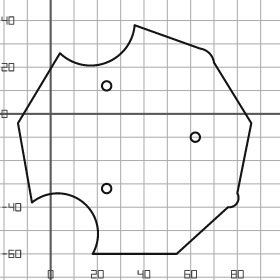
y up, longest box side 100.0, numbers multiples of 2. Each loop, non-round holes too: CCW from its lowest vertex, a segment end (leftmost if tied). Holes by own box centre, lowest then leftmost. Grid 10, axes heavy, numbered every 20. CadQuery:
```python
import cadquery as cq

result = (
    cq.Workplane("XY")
    .moveTo(18.0, -60.0)
    .lineTo(54.0, -60.0)
    .lineTo(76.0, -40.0)
    .threePointArc((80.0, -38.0), (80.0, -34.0))
    .lineTo(86.0, -4.0)
    .lineTo(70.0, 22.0)
    .threePointArc((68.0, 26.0), (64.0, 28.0))
    .lineTo(36.0, 38.0)
    .threePointArc((24.0, 22.0), (4.0, 26.0))
    .lineTo(-14.0, -4.0)
    .lineTo(-8.0, -38.0)
    .threePointArc((14.0, -38.0), (18.0, -60.0))
    .close()
    .moveTo(24.0, -32.0)
    .circle(2.0)
    .moveTo(62.0, -10.0)
    .circle(2.0)
    .moveTo(24.0, 12.0)
    .circle(2.0)
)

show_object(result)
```